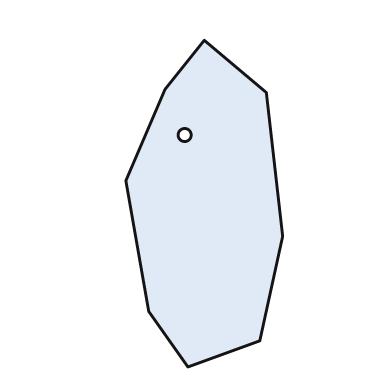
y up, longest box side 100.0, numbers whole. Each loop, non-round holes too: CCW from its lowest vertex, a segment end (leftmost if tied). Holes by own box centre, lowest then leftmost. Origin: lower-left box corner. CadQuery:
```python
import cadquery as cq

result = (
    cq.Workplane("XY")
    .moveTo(19.0, 0.0)
    .lineTo(41.0, 8.0)
    .lineTo(48.0, 40.0)
    .lineTo(43.0, 84.0)
    .lineTo(24.0, 100.0)
    .lineTo(12.0, 85.0)
    .lineTo(0.0, 57.0)
    .lineTo(7.0, 17.0)
    .close()
    .moveTo(18.0, 71.0)
    .circle(2.0)
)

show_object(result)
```